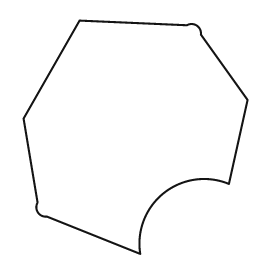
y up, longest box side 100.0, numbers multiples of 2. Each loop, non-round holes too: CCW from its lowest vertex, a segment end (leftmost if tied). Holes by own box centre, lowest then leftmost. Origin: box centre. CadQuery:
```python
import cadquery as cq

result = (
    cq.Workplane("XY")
    .moveTo(2.0, -50.0)
    .threePointArc((12.0, -24.0), (40.0, -20.0))
    .lineTo(48.0, 16.0)
    .lineTo(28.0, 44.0)
    .threePointArc((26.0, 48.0), (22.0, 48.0))
    .lineTo(-24.0, 50.0)
    .lineTo(-48.0, 8.0)
    .lineTo(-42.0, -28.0)
    .threePointArc((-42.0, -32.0), (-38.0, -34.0))
    .close()
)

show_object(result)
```